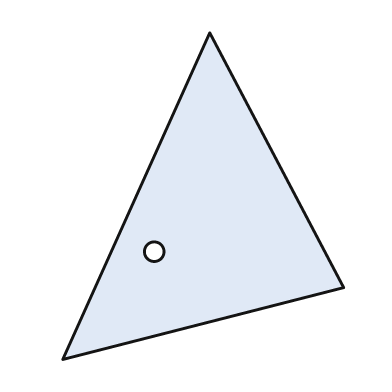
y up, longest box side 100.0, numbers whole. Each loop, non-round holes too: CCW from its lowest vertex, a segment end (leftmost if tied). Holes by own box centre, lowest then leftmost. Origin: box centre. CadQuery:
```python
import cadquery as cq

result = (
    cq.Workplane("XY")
    .moveTo(-43.0, -50.0)
    .lineTo(43.0, -28.0)
    .lineTo(2.0, 50.0)
    .close()
    .moveTo(-15.0, -17.0)
    .circle(3.0)
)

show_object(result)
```